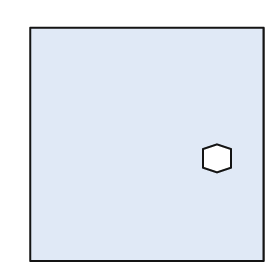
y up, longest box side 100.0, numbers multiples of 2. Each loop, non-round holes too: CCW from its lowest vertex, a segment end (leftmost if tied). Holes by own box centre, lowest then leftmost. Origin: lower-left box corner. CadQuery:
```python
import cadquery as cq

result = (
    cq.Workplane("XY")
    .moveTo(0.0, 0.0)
    .lineTo(100.0, 0.0)
    .lineTo(100.0, 100.0)
    .lineTo(0.0, 100.0)
    .close()
    .moveTo(80.0, 38.0)
    .lineTo(86.0, 40.0)
    .lineTo(86.0, 48.0)
    .lineTo(80.0, 50.0)
    .lineTo(74.0, 48.0)
    .lineTo(74.0, 40.0)
    .close()
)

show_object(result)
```